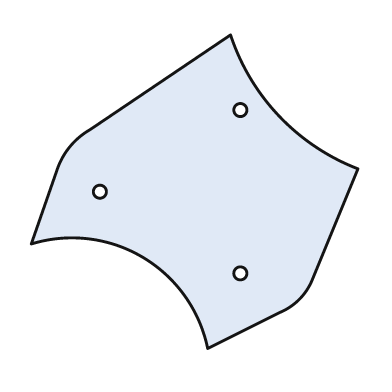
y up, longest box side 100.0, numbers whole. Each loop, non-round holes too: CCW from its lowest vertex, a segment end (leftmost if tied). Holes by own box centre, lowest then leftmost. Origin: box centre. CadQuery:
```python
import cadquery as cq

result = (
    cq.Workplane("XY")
    .moveTo(4.0, -48.0)
    .lineTo(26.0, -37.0)
    .threePointArc((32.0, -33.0), (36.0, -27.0))
    .lineTo(50.0, 7.0)
    .threePointArc((26.0, 23.0), (11.0, 48.0))
    .lineTo(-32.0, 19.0)
    .threePointArc((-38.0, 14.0), (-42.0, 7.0))
    .lineTo(-50.0, -16.0)
    .threePointArc((-16.0, -20.0), (4.0, -48.0))
    .close()
    .moveTo(14.0, -25.0)
    .circle(2.0)
    .moveTo(-29.0, 0.0)
    .circle(2.0)
    .moveTo(14.0, 25.0)
    .circle(2.0)
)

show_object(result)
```